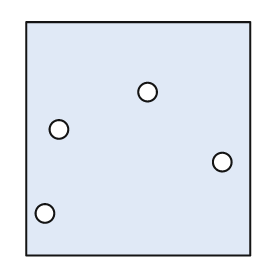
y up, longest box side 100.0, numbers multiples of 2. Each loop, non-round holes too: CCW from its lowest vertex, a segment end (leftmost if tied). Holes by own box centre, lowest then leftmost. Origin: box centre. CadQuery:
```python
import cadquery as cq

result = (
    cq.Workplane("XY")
    .moveTo(-48.0, -50.0)
    .lineTo(48.0, -50.0)
    .lineTo(48.0, 50.0)
    .lineTo(-48.0, 50.0)
    .close()
    .moveTo(-40.0, -32.0)
    .circle(4.0)
    .moveTo(36.0, -10.0)
    .circle(4.0)
    .moveTo(-34.0, 4.0)
    .circle(4.0)
    .moveTo(4.0, 20.0)
    .circle(4.0)
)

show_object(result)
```